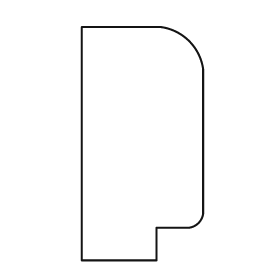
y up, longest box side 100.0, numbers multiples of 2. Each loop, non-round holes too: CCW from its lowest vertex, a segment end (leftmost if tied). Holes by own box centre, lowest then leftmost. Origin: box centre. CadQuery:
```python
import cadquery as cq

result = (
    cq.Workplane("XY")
    .moveTo(-26.0, -50.0)
    .lineTo(6.0, -50.0)
    .lineTo(6.0, -36.0)
    .lineTo(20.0, -36.0)
    .threePointArc((24.0, -34.0), (26.0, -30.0))
    .lineTo(26.0, 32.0)
    .threePointArc((20.0, 44.0), (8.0, 50.0))
    .lineTo(-26.0, 50.0)
    .close()
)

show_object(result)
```